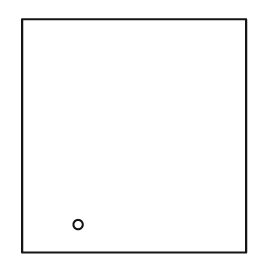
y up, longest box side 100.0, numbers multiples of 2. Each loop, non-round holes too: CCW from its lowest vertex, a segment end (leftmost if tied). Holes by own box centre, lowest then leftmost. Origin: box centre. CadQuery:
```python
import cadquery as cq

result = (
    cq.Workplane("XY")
    .moveTo(-48.0, -50.0)
    .lineTo(48.0, -50.0)
    .lineTo(48.0, 50.0)
    .lineTo(-48.0, 50.0)
    .close()
    .moveTo(-24.0, -38.0)
    .circle(2.0)
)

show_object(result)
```